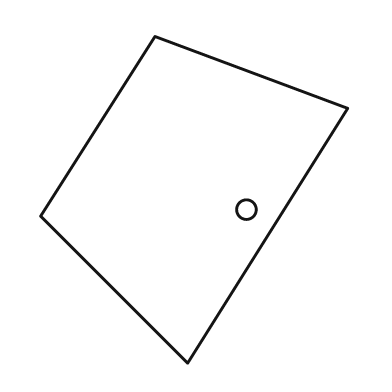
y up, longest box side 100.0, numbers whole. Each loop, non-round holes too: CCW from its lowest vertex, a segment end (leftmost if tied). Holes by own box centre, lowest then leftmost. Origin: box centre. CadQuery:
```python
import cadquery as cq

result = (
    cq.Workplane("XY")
    .moveTo(-2.0, -50.0)
    .lineTo(47.0, 28.0)
    .lineTo(-12.0, 50.0)
    .lineTo(-47.0, -5.0)
    .close()
    .moveTo(16.0, -3.0)
    .circle(3.0)
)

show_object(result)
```